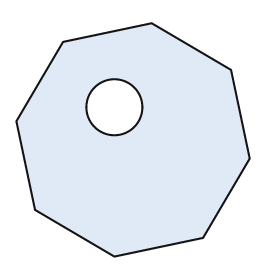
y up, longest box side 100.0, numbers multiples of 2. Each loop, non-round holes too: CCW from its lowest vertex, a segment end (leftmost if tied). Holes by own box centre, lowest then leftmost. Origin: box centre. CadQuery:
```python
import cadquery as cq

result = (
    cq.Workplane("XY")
    .moveTo(-8.0, -50.0)
    .lineTo(30.0, -42.0)
    .lineTo(50.0, -8.0)
    .lineTo(42.0, 30.0)
    .lineTo(8.0, 50.0)
    .lineTo(-30.0, 42.0)
    .lineTo(-50.0, 8.0)
    .lineTo(-42.0, -30.0)
    .close()
    .moveTo(-8.0, 14.0)
    .circle(12.0)
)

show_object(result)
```